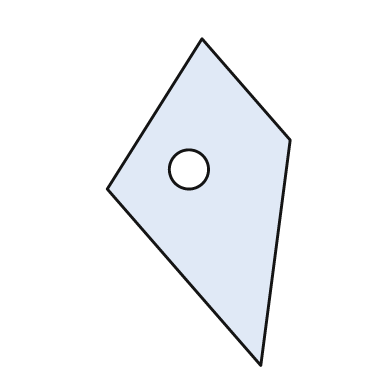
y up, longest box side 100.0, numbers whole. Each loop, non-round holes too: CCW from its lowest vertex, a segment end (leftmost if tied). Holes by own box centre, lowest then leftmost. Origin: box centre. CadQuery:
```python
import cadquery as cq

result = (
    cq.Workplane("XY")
    .moveTo(19.0, -50.0)
    .lineTo(28.0, 19.0)
    .lineTo(1.0, 50.0)
    .lineTo(-28.0, 4.0)
    .close()
    .moveTo(-3.0, 10.0)
    .circle(6.0)
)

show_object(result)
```